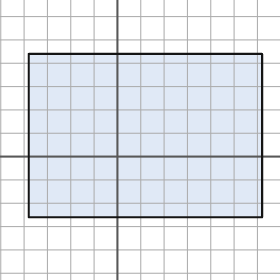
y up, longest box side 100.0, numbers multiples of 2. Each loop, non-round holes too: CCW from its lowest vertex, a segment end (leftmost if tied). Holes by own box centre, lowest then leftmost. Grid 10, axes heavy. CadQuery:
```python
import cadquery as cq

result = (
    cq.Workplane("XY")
    .moveTo(-38.0, -26.0)
    .lineTo(62.0, -26.0)
    .lineTo(62.0, 44.0)
    .lineTo(-38.0, 44.0)
    .close()
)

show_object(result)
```